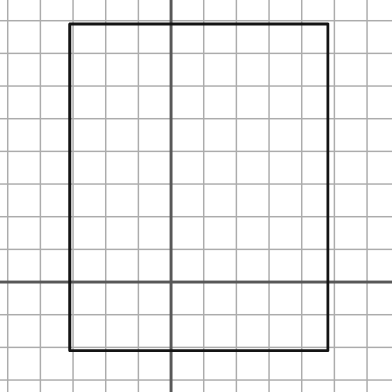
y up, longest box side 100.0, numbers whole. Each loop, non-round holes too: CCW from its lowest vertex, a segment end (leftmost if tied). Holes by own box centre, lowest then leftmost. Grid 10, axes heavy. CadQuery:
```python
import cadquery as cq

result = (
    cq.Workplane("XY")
    .moveTo(-31.0, -21.0)
    .lineTo(48.0, -21.0)
    .lineTo(48.0, 79.0)
    .lineTo(-31.0, 79.0)
    .close()
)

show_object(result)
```